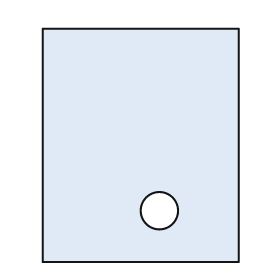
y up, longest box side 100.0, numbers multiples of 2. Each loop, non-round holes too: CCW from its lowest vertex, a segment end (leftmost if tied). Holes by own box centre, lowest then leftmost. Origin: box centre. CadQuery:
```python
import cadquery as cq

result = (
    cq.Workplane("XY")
    .moveTo(-42.0, -50.0)
    .lineTo(42.0, -50.0)
    .lineTo(42.0, 50.0)
    .lineTo(-42.0, 50.0)
    .close()
    .moveTo(8.0, -28.0)
    .circle(8.0)
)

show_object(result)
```